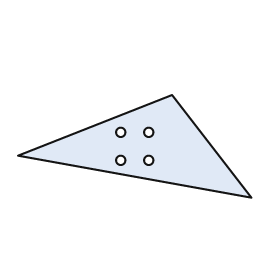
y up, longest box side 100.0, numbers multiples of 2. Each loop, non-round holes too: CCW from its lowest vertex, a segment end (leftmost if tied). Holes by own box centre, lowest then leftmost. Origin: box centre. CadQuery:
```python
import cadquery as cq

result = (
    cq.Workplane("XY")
    .moveTo(50.0, -22.0)
    .lineTo(16.0, 22.0)
    .lineTo(-50.0, -4.0)
    .close()
    .moveTo(-6.0, -6.0)
    .circle(2.0)
    .moveTo(6.0, -6.0)
    .circle(2.0)
    .moveTo(-6.0, 6.0)
    .circle(2.0)
    .moveTo(6.0, 6.0)
    .circle(2.0)
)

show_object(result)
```